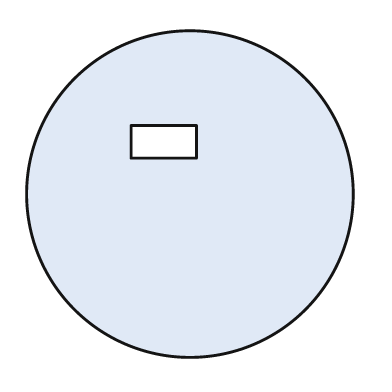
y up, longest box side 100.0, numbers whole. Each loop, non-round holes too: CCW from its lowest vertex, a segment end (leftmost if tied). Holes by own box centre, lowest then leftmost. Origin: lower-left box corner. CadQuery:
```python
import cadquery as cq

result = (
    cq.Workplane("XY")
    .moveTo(50.0, 50.0)
    .circle(50.0)
    .moveTo(32.0, 61.0)
    .lineTo(52.0, 61.0)
    .lineTo(52.0, 71.0)
    .lineTo(32.0, 71.0)
    .close()
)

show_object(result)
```